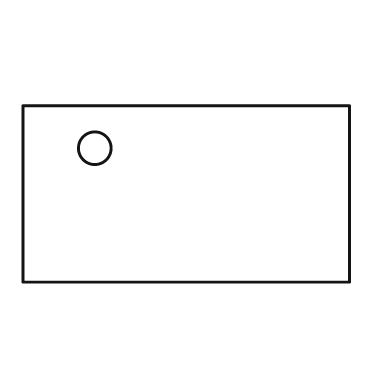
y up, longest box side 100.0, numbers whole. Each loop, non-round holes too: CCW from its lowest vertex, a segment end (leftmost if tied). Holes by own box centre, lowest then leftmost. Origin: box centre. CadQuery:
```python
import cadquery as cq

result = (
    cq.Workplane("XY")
    .moveTo(-50.0, -27.0)
    .lineTo(50.0, -27.0)
    .lineTo(50.0, 27.0)
    .lineTo(-50.0, 27.0)
    .close()
    .moveTo(-28.0, 14.0)
    .circle(5.0)
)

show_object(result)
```